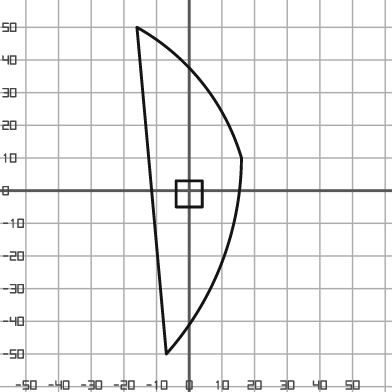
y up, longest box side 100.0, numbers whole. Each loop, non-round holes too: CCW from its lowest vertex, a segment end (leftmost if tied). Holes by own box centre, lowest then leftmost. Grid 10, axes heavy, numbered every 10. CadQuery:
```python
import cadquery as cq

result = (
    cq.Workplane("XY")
    .moveTo(-7.0, -50.0)
    .threePointArc((10.0, -22.0), (16.0, 10.0))
    .threePointArc((4.0, 33.0), (-16.0, 50.0))
    .close()
    .moveTo(-4.0, -5.0)
    .lineTo(4.0, -5.0)
    .lineTo(4.0, 3.0)
    .lineTo(-4.0, 3.0)
    .close()
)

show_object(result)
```